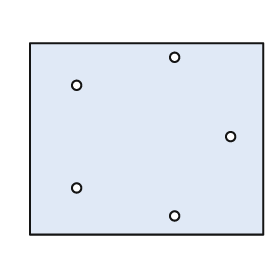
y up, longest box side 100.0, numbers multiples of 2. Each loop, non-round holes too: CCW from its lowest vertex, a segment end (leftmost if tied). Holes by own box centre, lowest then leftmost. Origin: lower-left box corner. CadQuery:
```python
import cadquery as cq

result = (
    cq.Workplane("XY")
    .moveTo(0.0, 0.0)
    .lineTo(100.0, 0.0)
    .lineTo(100.0, 82.0)
    .lineTo(0.0, 82.0)
    .close()
    .moveTo(62.0, 8.0)
    .circle(2.0)
    .moveTo(20.0, 20.0)
    .circle(2.0)
    .moveTo(86.0, 42.0)
    .circle(2.0)
    .moveTo(20.0, 64.0)
    .circle(2.0)
    .moveTo(62.0, 76.0)
    .circle(2.0)
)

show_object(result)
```